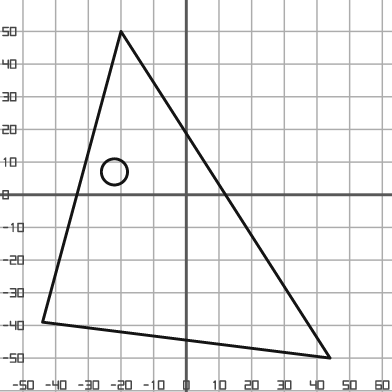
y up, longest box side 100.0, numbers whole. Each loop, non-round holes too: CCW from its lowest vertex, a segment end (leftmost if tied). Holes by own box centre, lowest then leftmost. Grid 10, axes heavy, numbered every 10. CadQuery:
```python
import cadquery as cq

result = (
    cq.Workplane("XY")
    .moveTo(44.0, -50.0)
    .lineTo(-20.0, 50.0)
    .lineTo(-44.0, -39.0)
    .close()
    .moveTo(-22.0, 7.0)
    .circle(4.0)
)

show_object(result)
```